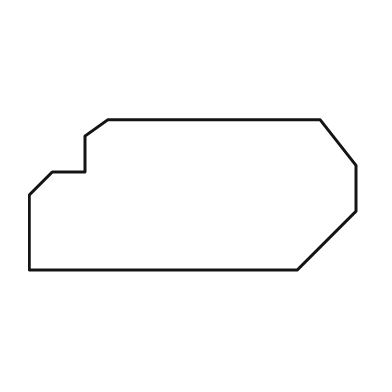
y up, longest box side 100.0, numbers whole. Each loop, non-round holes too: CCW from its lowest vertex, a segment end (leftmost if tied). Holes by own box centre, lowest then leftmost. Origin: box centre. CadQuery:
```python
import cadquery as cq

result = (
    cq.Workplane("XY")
    .moveTo(-50.0, -23.0)
    .lineTo(32.0, -23.0)
    .lineTo(50.0, -5.0)
    .lineTo(50.0, 9.0)
    .lineTo(39.0, 23.0)
    .lineTo(-26.0, 23.0)
    .lineTo(-33.0, 18.0)
    .lineTo(-33.0, 7.0)
    .lineTo(-43.0, 7.0)
    .lineTo(-50.0, 0.0)
    .close()
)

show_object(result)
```